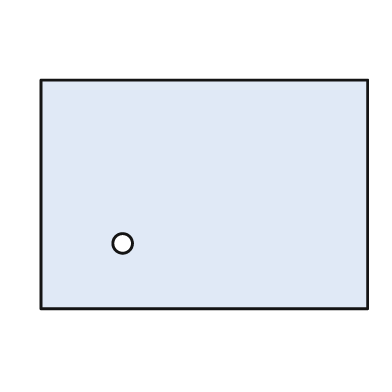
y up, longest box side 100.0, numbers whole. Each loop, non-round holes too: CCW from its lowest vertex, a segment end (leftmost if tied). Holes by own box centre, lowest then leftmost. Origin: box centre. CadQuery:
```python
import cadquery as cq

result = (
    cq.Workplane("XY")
    .moveTo(-50.0, -35.0)
    .lineTo(50.0, -35.0)
    .lineTo(50.0, 35.0)
    .lineTo(-50.0, 35.0)
    .close()
    .moveTo(-25.0, -15.0)
    .circle(3.0)
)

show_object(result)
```